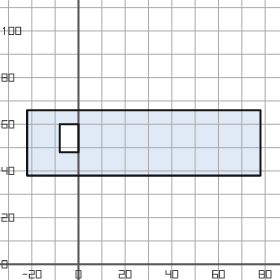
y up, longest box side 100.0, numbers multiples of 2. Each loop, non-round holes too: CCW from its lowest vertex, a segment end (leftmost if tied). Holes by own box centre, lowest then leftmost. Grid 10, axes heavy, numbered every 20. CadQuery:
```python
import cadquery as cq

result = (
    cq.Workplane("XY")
    .moveTo(-22.0, 38.0)
    .lineTo(78.0, 38.0)
    .lineTo(78.0, 66.0)
    .lineTo(-22.0, 66.0)
    .close()
    .moveTo(-8.0, 48.0)
    .lineTo(0.0, 48.0)
    .lineTo(0.0, 60.0)
    .lineTo(-8.0, 60.0)
    .close()
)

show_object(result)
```